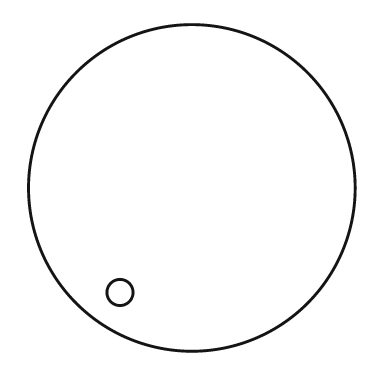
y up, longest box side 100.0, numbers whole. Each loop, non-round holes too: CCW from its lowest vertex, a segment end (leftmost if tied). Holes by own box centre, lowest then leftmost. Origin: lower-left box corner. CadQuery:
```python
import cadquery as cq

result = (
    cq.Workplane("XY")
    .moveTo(50.0, 50.0)
    .circle(50.0)
    .moveTo(28.0, 18.0)
    .circle(4.0)
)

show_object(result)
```